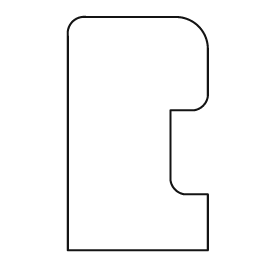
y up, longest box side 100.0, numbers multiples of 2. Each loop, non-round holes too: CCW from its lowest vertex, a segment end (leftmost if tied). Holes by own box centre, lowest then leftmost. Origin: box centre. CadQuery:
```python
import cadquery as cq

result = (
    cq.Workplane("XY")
    .moveTo(-30.0, -50.0)
    .lineTo(30.0, -50.0)
    .lineTo(30.0, -26.0)
    .lineTo(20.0, -26.0)
    .threePointArc((16.0, -24.0), (14.0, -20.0))
    .lineTo(14.0, 10.0)
    .lineTo(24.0, 10.0)
    .threePointArc((28.0, 12.0), (30.0, 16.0))
    .lineTo(30.0, 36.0)
    .threePointArc((26.0, 46.0), (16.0, 50.0))
    .lineTo(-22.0, 50.0)
    .threePointArc((-28.0, 48.0), (-30.0, 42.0))
    .close()
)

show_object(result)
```